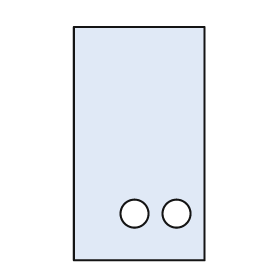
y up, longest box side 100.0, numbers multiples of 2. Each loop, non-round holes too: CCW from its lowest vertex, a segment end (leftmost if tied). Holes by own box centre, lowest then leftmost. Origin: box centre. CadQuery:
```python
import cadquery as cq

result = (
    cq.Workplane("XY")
    .moveTo(-28.0, -50.0)
    .lineTo(28.0, -50.0)
    .lineTo(28.0, 50.0)
    .lineTo(-28.0, 50.0)
    .close()
    .moveTo(-2.0, -30.0)
    .circle(6.0)
    .moveTo(16.0, -30.0)
    .circle(6.0)
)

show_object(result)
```